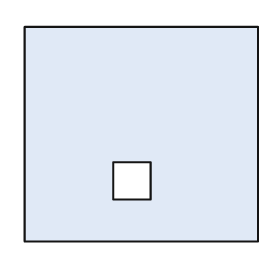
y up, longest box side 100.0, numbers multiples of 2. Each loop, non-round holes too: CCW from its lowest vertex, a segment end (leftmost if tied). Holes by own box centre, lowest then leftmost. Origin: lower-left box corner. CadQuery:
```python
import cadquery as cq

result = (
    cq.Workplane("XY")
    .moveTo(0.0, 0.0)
    .lineTo(100.0, 0.0)
    .lineTo(100.0, 92.0)
    .lineTo(0.0, 92.0)
    .close()
    .moveTo(38.0, 18.0)
    .lineTo(54.0, 18.0)
    .lineTo(54.0, 34.0)
    .lineTo(38.0, 34.0)
    .close()
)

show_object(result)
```